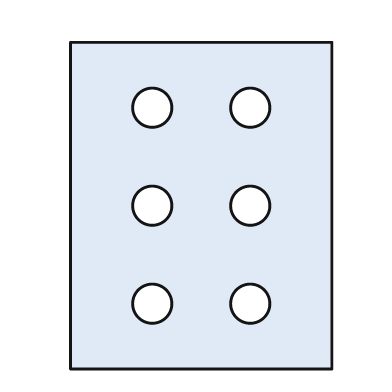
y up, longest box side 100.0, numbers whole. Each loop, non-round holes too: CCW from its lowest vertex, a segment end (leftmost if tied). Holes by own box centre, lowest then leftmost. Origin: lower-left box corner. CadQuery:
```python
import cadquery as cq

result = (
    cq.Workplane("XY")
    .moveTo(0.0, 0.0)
    .lineTo(80.0, 0.0)
    .lineTo(80.0, 100.0)
    .lineTo(0.0, 100.0)
    .close()
    .moveTo(25.0, 20.0)
    .circle(6.0)
    .moveTo(55.0, 20.0)
    .circle(6.0)
    .moveTo(25.0, 50.0)
    .circle(6.0)
    .moveTo(55.0, 50.0)
    .circle(6.0)
    .moveTo(25.0, 80.0)
    .circle(6.0)
    .moveTo(55.0, 80.0)
    .circle(6.0)
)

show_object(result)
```